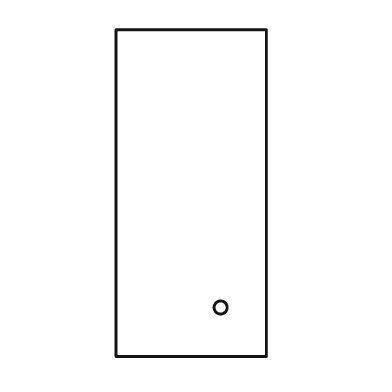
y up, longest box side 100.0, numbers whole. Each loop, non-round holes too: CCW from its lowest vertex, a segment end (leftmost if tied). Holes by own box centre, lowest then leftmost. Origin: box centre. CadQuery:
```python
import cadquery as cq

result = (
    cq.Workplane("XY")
    .moveTo(-23.0, -50.0)
    .lineTo(23.0, -50.0)
    .lineTo(23.0, 50.0)
    .lineTo(-23.0, 50.0)
    .close()
    .moveTo(9.0, -35.0)
    .circle(2.0)
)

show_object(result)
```